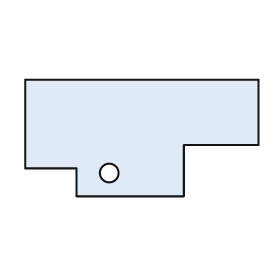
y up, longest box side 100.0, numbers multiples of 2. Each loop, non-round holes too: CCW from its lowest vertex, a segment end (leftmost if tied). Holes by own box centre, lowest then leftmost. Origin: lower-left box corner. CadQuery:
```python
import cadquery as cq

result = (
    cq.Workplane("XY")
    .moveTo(22.0, 0.0)
    .lineTo(68.0, 0.0)
    .lineTo(68.0, 22.0)
    .lineTo(100.0, 22.0)
    .lineTo(100.0, 50.0)
    .lineTo(0.0, 50.0)
    .lineTo(0.0, 12.0)
    .lineTo(22.0, 12.0)
    .close()
    .moveTo(36.0, 10.0)
    .circle(4.0)
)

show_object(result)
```